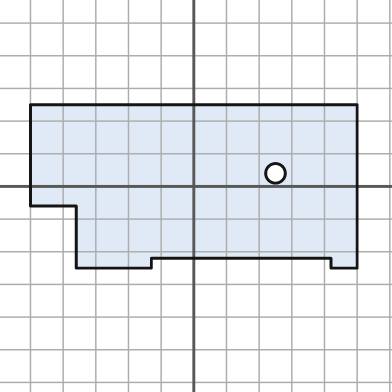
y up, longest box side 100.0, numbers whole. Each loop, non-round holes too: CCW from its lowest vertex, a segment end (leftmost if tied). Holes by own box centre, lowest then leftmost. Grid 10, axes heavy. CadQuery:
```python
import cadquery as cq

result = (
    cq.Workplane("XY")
    .moveTo(-36.0, -25.0)
    .lineTo(-13.0, -25.0)
    .lineTo(-13.0, -22.0)
    .lineTo(42.0, -22.0)
    .lineTo(42.0, -25.0)
    .lineTo(50.0, -25.0)
    .lineTo(50.0, 25.0)
    .lineTo(-50.0, 25.0)
    .lineTo(-50.0, -6.0)
    .lineTo(-36.0, -6.0)
    .close()
    .moveTo(25.0, 4.0)
    .circle(3.0)
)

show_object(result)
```